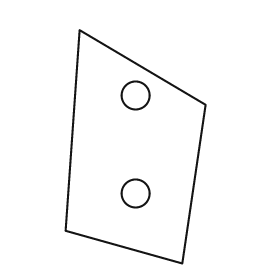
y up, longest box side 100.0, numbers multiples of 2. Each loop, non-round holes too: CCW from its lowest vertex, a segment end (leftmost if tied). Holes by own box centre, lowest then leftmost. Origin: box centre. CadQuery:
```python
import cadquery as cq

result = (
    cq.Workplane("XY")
    .moveTo(20.0, -50.0)
    .lineTo(30.0, 18.0)
    .lineTo(-24.0, 50.0)
    .lineTo(-30.0, -36.0)
    .close()
    .moveTo(0.0, -20.0)
    .circle(6.0)
    .moveTo(0.0, 22.0)
    .circle(6.0)
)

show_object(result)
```